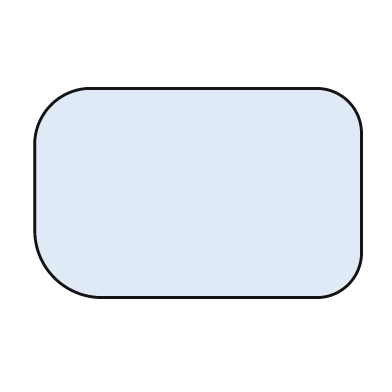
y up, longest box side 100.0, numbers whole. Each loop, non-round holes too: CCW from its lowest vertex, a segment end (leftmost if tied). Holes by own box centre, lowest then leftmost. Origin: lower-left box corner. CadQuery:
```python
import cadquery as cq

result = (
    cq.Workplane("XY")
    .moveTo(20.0, 0.0)
    .lineTo(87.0, 0.0)
    .threePointArc((96.0, 4.0), (100.0, 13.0))
    .lineTo(100.0, 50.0)
    .threePointArc((96.0, 60.0), (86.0, 64.0))
    .lineTo(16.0, 64.0)
    .threePointArc((5.0, 59.0), (0.0, 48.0))
    .lineTo(0.0, 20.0)
    .threePointArc((6.0, 6.0), (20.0, 0.0))
    .close()
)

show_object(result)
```